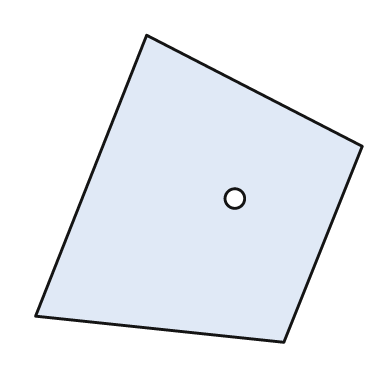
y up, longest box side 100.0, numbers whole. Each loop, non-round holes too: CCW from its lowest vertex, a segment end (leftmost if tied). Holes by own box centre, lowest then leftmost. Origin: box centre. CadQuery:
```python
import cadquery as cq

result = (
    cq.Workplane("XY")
    .moveTo(26.0, -47.0)
    .lineTo(50.0, 13.0)
    .lineTo(-16.0, 47.0)
    .lineTo(-50.0, -39.0)
    .close()
    .moveTo(11.0, -3.0)
    .circle(3.0)
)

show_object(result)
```